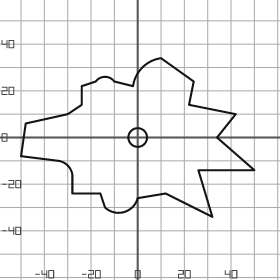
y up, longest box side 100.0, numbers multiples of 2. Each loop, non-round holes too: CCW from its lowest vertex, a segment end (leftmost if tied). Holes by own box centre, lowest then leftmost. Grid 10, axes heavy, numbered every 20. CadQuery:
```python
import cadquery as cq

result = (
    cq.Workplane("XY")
    .moveTo(32.0, -34.0)
    .lineTo(26.0, -14.0)
    .lineTo(50.0, -14.0)
    .lineTo(34.0, 0.0)
    .lineTo(42.0, 10.0)
    .lineTo(22.0, 14.0)
    .lineTo(24.0, 24.0)
    .lineTo(10.0, 34.0)
    .threePointArc((2.0, 30.0), (-2.0, 22.0))
    .lineTo(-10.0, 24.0)
    .threePointArc((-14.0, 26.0), (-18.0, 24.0))
    .lineTo(-24.0, 22.0)
    .lineTo(-24.0, 14.0)
    .lineTo(-30.0, 10.0)
    .lineTo(-48.0, 6.0)
    .lineTo(-50.0, -8.0)
    .lineTo(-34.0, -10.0)
    .threePointArc((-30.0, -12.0), (-28.0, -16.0))
    .lineTo(-28.0, -24.0)
    .lineTo(-16.0, -24.0)
    .lineTo(-14.0, -30.0)
    .threePointArc((-6.0, -32.0), (0.0, -26.0))
    .lineTo(12.0, -24.0)
    .close()
    .moveTo(0.0, 0.0)
    .circle(4.0)
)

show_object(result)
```